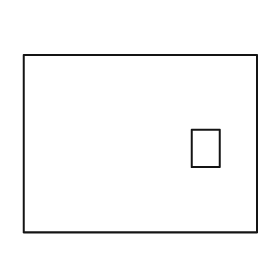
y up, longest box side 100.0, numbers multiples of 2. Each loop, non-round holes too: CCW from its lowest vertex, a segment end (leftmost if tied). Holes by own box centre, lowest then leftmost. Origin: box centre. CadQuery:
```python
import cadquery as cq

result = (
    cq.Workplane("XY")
    .moveTo(-50.0, -38.0)
    .lineTo(50.0, -38.0)
    .lineTo(50.0, 38.0)
    .lineTo(-50.0, 38.0)
    .close()
    .moveTo(22.0, -10.0)
    .lineTo(34.0, -10.0)
    .lineTo(34.0, 6.0)
    .lineTo(22.0, 6.0)
    .close()
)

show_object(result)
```